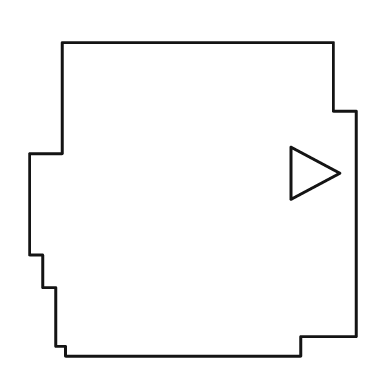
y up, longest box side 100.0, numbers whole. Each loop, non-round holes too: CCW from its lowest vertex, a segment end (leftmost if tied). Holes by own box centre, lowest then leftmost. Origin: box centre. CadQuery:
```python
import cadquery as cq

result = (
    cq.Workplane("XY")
    .moveTo(-39.0, -48.0)
    .lineTo(33.0, -48.0)
    .lineTo(33.0, -42.0)
    .lineTo(50.0, -42.0)
    .lineTo(50.0, 27.0)
    .lineTo(43.0, 27.0)
    .lineTo(43.0, 48.0)
    .lineTo(-40.0, 48.0)
    .lineTo(-40.0, 14.0)
    .lineTo(-50.0, 14.0)
    .lineTo(-50.0, -17.0)
    .lineTo(-46.0, -17.0)
    .lineTo(-46.0, -27.0)
    .lineTo(-42.0, -27.0)
    .lineTo(-42.0, -45.0)
    .lineTo(-39.0, -45.0)
    .close()
    .moveTo(30.0, 0.0)
    .lineTo(45.0, 8.0)
    .lineTo(30.0, 16.0)
    .close()
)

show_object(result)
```